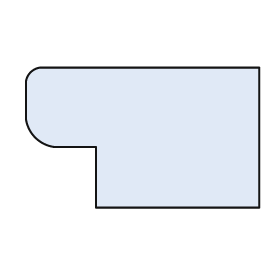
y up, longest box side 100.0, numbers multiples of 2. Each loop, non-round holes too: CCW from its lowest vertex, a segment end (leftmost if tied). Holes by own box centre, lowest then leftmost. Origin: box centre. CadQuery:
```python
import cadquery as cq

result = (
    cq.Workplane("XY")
    .moveTo(-20.0, -30.0)
    .lineTo(50.0, -30.0)
    .lineTo(50.0, 30.0)
    .lineTo(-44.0, 30.0)
    .threePointArc((-48.0, 28.0), (-50.0, 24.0))
    .lineTo(-50.0, 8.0)
    .threePointArc((-46.0, 0.0), (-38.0, -4.0))
    .lineTo(-20.0, -4.0)
    .close()
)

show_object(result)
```